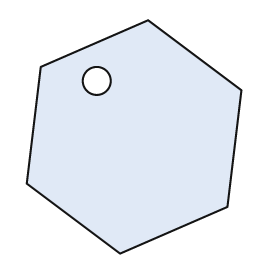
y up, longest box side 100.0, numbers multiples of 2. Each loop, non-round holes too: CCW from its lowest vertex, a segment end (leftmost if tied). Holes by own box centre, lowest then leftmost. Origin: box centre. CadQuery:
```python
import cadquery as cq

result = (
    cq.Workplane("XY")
    .moveTo(-6.0, -50.0)
    .lineTo(40.0, -30.0)
    .lineTo(46.0, 20.0)
    .lineTo(6.0, 50.0)
    .lineTo(-40.0, 30.0)
    .lineTo(-46.0, -20.0)
    .close()
    .moveTo(-16.0, 24.0)
    .circle(6.0)
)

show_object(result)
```